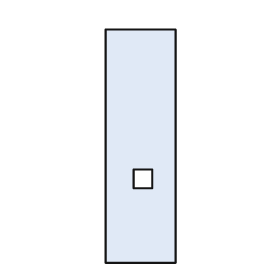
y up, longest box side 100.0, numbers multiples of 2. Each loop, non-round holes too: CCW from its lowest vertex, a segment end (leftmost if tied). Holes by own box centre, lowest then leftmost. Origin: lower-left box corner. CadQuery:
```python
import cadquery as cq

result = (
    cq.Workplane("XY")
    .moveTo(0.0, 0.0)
    .lineTo(30.0, 0.0)
    .lineTo(30.0, 100.0)
    .lineTo(0.0, 100.0)
    .close()
    .moveTo(12.0, 32.0)
    .lineTo(20.0, 32.0)
    .lineTo(20.0, 40.0)
    .lineTo(12.0, 40.0)
    .close()
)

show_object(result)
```